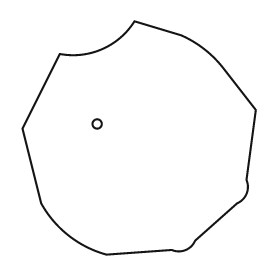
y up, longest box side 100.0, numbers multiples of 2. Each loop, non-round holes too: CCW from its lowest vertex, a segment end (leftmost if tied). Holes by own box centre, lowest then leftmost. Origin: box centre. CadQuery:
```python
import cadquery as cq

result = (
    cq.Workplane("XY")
    .moveTo(-14.0, -50.0)
    .lineTo(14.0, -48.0)
    .threePointArc((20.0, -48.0), (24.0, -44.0))
    .lineTo(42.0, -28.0)
    .threePointArc((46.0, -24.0), (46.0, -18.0))
    .lineTo(50.0, 12.0)
    .lineTo(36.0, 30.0)
    .threePointArc((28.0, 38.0), (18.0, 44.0))
    .lineTo(-2.0, 50.0)
    .threePointArc((-16.0, 38.0), (-34.0, 36.0))
    .lineTo(-50.0, 4.0)
    .lineTo(-42.0, -28.0)
    .threePointArc((-30.0, -42.0), (-14.0, -50.0))
    .close()
    .moveTo(-18.0, 6.0)
    .circle(2.0)
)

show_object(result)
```